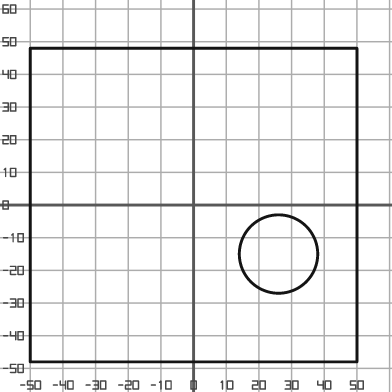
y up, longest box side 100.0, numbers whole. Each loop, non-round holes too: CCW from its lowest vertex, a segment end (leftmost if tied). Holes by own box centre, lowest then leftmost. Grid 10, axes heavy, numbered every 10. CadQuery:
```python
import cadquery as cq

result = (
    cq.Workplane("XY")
    .moveTo(-50.0, -48.0)
    .lineTo(50.0, -48.0)
    .lineTo(50.0, 48.0)
    .lineTo(-50.0, 48.0)
    .close()
    .moveTo(26.0, -15.0)
    .circle(12.0)
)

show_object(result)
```